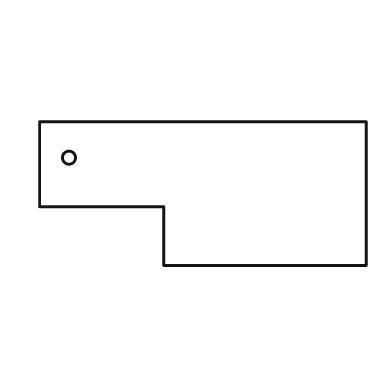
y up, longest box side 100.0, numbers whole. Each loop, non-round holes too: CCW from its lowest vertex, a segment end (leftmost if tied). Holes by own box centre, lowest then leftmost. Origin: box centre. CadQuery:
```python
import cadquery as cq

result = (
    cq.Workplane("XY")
    .moveTo(-12.0, -22.0)
    .lineTo(50.0, -22.0)
    .lineTo(50.0, 22.0)
    .lineTo(-50.0, 22.0)
    .lineTo(-50.0, -4.0)
    .lineTo(-12.0, -4.0)
    .close()
    .moveTo(-41.0, 11.0)
    .circle(2.0)
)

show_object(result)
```